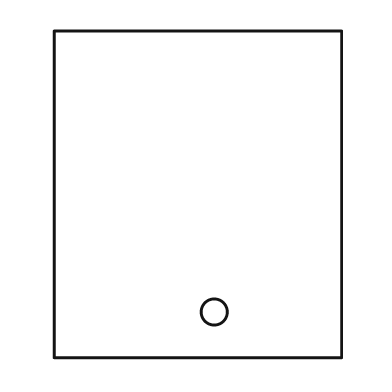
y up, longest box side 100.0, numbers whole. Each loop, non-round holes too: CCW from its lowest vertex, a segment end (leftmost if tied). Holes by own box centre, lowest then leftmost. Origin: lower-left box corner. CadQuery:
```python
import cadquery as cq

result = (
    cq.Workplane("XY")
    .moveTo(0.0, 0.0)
    .lineTo(88.0, 0.0)
    .lineTo(88.0, 100.0)
    .lineTo(0.0, 100.0)
    .close()
    .moveTo(49.0, 14.0)
    .circle(4.0)
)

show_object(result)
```